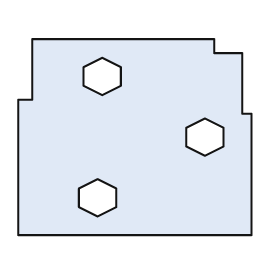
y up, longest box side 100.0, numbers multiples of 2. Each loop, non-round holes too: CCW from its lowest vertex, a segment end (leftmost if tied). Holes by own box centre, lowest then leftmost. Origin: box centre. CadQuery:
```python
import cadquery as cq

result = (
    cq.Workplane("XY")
    .moveTo(-50.0, -42.0)
    .lineTo(50.0, -42.0)
    .lineTo(50.0, 10.0)
    .lineTo(46.0, 10.0)
    .lineTo(46.0, 36.0)
    .lineTo(34.0, 36.0)
    .lineTo(34.0, 42.0)
    .lineTo(-44.0, 42.0)
    .lineTo(-44.0, 16.0)
    .lineTo(-50.0, 16.0)
    .close()
    .moveTo(-16.0, -34.0)
    .lineTo(-8.0, -30.0)
    .lineTo(-8.0, -22.0)
    .lineTo(-16.0, -18.0)
    .lineTo(-24.0, -22.0)
    .lineTo(-24.0, -30.0)
    .close()
    .moveTo(30.0, -8.0)
    .lineTo(38.0, -4.0)
    .lineTo(38.0, 4.0)
    .lineTo(30.0, 8.0)
    .lineTo(22.0, 4.0)
    .lineTo(22.0, -4.0)
    .close()
    .moveTo(-14.0, 18.0)
    .lineTo(-6.0, 22.0)
    .lineTo(-6.0, 30.0)
    .lineTo(-14.0, 34.0)
    .lineTo(-22.0, 30.0)
    .lineTo(-22.0, 22.0)
    .close()
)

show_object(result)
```